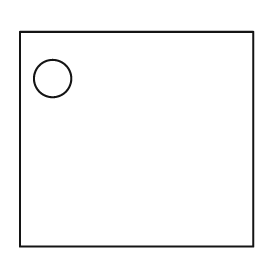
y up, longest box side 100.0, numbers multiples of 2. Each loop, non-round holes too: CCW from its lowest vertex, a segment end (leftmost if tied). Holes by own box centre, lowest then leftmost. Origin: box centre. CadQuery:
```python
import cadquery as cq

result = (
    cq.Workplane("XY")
    .moveTo(-50.0, -46.0)
    .lineTo(50.0, -46.0)
    .lineTo(50.0, 46.0)
    .lineTo(-50.0, 46.0)
    .close()
    .moveTo(-36.0, 26.0)
    .circle(8.0)
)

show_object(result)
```